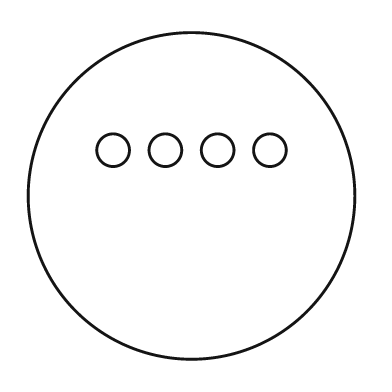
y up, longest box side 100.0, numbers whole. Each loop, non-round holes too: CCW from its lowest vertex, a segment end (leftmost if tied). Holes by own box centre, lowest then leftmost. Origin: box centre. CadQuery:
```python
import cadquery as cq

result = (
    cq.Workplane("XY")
    .moveTo(0.0, 0.0)
    .circle(50.0)
    .moveTo(-24.0, 14.0)
    .circle(5.0)
    .moveTo(-8.0, 14.0)
    .circle(5.0)
    .moveTo(8.0, 14.0)
    .circle(5.0)
    .moveTo(24.0, 14.0)
    .circle(5.0)
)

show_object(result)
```